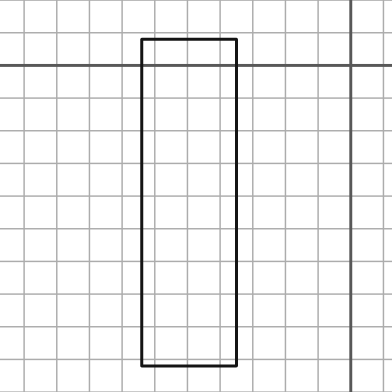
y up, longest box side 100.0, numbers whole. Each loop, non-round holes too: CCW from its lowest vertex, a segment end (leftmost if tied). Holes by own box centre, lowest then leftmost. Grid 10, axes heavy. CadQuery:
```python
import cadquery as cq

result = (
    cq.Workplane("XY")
    .moveTo(-64.0, -92.0)
    .lineTo(-35.0, -92.0)
    .lineTo(-35.0, 8.0)
    .lineTo(-64.0, 8.0)
    .close()
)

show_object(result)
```